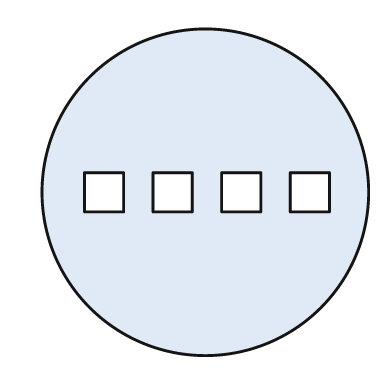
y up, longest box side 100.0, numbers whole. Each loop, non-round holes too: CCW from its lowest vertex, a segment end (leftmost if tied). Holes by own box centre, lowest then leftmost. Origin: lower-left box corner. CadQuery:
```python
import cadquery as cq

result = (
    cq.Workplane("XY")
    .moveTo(50.0, 50.0)
    .circle(50.0)
    .moveTo(13.0, 44.0)
    .lineTo(25.0, 44.0)
    .lineTo(25.0, 56.0)
    .lineTo(13.0, 56.0)
    .close()
    .moveTo(34.0, 44.0)
    .lineTo(46.0, 44.0)
    .lineTo(46.0, 56.0)
    .lineTo(34.0, 56.0)
    .close()
    .moveTo(55.0, 44.0)
    .lineTo(67.0, 44.0)
    .lineTo(67.0, 56.0)
    .lineTo(55.0, 56.0)
    .close()
    .moveTo(76.0, 44.0)
    .lineTo(88.0, 44.0)
    .lineTo(88.0, 56.0)
    .lineTo(76.0, 56.0)
    .close()
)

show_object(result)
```